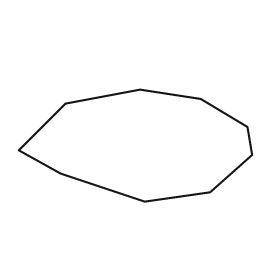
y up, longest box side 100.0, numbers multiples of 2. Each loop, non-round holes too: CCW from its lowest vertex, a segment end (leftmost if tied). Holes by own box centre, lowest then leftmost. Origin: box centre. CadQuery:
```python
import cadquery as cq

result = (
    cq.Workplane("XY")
    .moveTo(4.0, -24.0)
    .lineTo(32.0, -20.0)
    .lineTo(50.0, -4.0)
    .lineTo(48.0, 8.0)
    .lineTo(28.0, 20.0)
    .lineTo(2.0, 24.0)
    .lineTo(-30.0, 18.0)
    .lineTo(-50.0, -2.0)
    .lineTo(-32.0, -12.0)
    .close()
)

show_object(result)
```